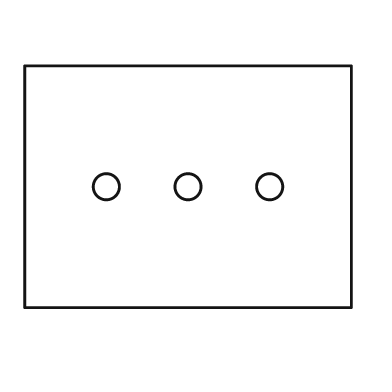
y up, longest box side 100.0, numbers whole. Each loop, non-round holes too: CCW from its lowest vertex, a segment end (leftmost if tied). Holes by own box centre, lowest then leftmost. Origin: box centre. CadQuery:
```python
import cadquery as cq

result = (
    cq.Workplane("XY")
    .moveTo(-50.0, -37.0)
    .lineTo(50.0, -37.0)
    .lineTo(50.0, 37.0)
    .lineTo(-50.0, 37.0)
    .close()
    .moveTo(-25.0, 0.0)
    .circle(4.0)
    .moveTo(0.0, 0.0)
    .circle(4.0)
    .moveTo(25.0, 0.0)
    .circle(4.0)
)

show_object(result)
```